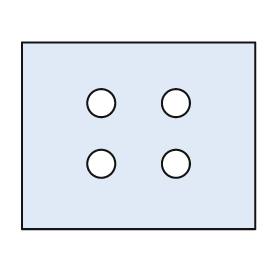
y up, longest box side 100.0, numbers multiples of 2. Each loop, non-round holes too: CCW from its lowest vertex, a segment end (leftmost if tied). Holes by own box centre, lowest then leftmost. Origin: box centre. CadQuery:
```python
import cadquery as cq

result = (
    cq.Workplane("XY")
    .moveTo(-50.0, -40.0)
    .lineTo(50.0, -40.0)
    .lineTo(50.0, 40.0)
    .lineTo(-50.0, 40.0)
    .close()
    .moveTo(-16.0, -12.0)
    .circle(6.0)
    .moveTo(16.0, -12.0)
    .circle(6.0)
    .moveTo(-16.0, 14.0)
    .circle(6.0)
    .moveTo(16.0, 14.0)
    .circle(6.0)
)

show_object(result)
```